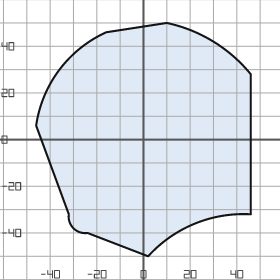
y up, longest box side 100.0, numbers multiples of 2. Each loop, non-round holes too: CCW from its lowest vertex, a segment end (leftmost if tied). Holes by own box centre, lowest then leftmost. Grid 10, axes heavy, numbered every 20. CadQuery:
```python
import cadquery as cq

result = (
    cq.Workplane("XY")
    .moveTo(2.0, -50.0)
    .threePointArc((22.0, -36.0), (46.0, -32.0))
    .lineTo(46.0, 28.0)
    .threePointArc((30.0, 42.0), (10.0, 50.0))
    .lineTo(-16.0, 46.0)
    .threePointArc((-36.0, 30.0), (-46.0, 6.0))
    .lineTo(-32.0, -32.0)
    .threePointArc((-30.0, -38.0), (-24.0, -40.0))
    .close()
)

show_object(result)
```